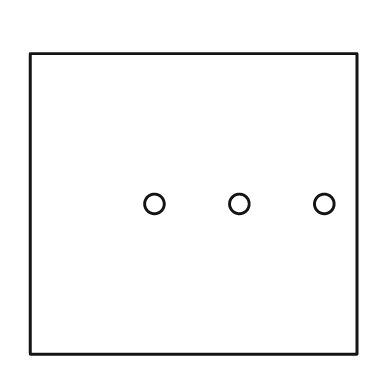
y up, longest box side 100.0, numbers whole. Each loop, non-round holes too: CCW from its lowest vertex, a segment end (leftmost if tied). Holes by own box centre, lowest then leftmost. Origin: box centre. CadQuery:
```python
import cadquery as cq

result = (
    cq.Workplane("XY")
    .moveTo(-50.0, -46.0)
    .lineTo(50.0, -46.0)
    .lineTo(50.0, 46.0)
    .lineTo(-50.0, 46.0)
    .close()
    .moveTo(-12.0, 0.0)
    .circle(3.0)
    .moveTo(14.0, 0.0)
    .circle(3.0)
    .moveTo(40.0, 0.0)
    .circle(3.0)
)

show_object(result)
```